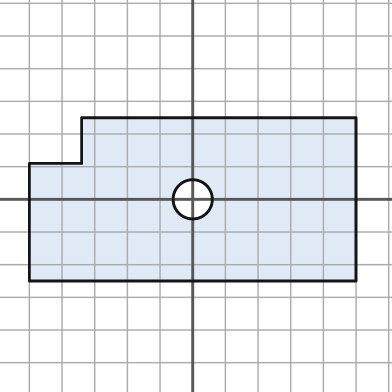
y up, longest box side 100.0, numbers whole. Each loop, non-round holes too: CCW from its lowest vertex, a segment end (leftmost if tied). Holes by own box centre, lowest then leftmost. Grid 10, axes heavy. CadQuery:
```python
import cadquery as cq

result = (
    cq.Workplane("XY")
    .moveTo(-50.0, -25.0)
    .lineTo(50.0, -25.0)
    .lineTo(50.0, 25.0)
    .lineTo(-34.0, 25.0)
    .lineTo(-34.0, 11.0)
    .lineTo(-50.0, 11.0)
    .close()
    .moveTo(0.0, 0.0)
    .circle(6.0)
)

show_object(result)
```